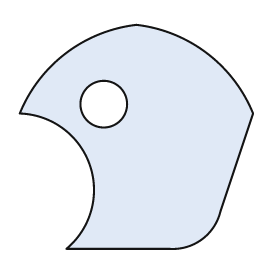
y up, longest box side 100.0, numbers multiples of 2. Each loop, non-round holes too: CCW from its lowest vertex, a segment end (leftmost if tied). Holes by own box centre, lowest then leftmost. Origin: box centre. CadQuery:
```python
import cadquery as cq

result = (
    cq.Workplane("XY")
    .moveTo(-30.0, -48.0)
    .lineTo(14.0, -48.0)
    .threePointArc((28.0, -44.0), (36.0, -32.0))
    .lineTo(50.0, 10.0)
    .threePointArc((30.0, 36.0), (0.0, 48.0))
    .threePointArc((-30.0, 36.0), (-50.0, 10.0))
    .threePointArc((-20.0, -12.0), (-30.0, -48.0))
    .close()
    .moveTo(-14.0, 14.0)
    .circle(10.0)
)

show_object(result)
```